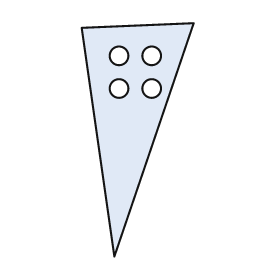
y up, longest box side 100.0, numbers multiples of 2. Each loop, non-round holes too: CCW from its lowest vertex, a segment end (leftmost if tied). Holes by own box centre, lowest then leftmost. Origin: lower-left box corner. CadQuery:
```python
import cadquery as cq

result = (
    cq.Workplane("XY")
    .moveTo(14.0, 0.0)
    .lineTo(48.0, 100.0)
    .lineTo(0.0, 98.0)
    .close()
    .moveTo(16.0, 72.0)
    .circle(4.0)
    .moveTo(30.0, 72.0)
    .circle(4.0)
    .moveTo(16.0, 86.0)
    .circle(4.0)
    .moveTo(30.0, 86.0)
    .circle(4.0)
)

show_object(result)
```